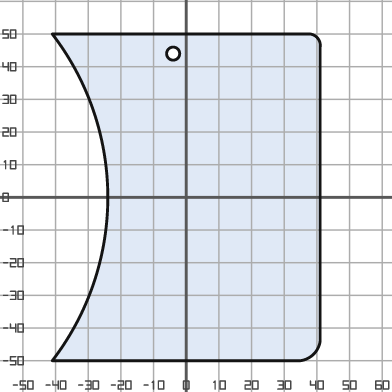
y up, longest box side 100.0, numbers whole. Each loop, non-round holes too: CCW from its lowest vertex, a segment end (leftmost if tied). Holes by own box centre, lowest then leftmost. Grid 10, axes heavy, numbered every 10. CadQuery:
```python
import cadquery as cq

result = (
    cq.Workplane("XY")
    .moveTo(-41.0, -50.0)
    .lineTo(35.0, -50.0)
    .threePointArc((39.0, -48.0), (41.0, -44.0))
    .lineTo(41.0, 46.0)
    .threePointArc((40.0, 49.0), (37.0, 50.0))
    .lineTo(-41.0, 50.0)
    .threePointArc((-24.0, 0.0), (-41.0, -50.0))
    .close()
    .moveTo(-4.0, 44.0)
    .circle(2.0)
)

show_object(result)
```